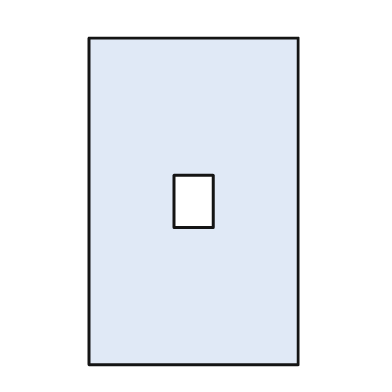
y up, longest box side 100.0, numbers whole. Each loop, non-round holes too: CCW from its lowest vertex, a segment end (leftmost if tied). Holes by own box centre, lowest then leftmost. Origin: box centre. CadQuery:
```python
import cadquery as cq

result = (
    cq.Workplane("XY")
    .moveTo(-32.0, -50.0)
    .lineTo(32.0, -50.0)
    .lineTo(32.0, 50.0)
    .lineTo(-32.0, 50.0)
    .close()
    .moveTo(-6.0, -8.0)
    .lineTo(6.0, -8.0)
    .lineTo(6.0, 8.0)
    .lineTo(-6.0, 8.0)
    .close()
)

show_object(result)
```